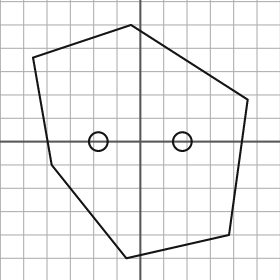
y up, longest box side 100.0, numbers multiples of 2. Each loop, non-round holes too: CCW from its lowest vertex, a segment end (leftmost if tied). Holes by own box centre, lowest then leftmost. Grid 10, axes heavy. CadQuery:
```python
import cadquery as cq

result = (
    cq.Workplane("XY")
    .moveTo(-6.0, -50.0)
    .lineTo(38.0, -40.0)
    .lineTo(46.0, 18.0)
    .lineTo(-4.0, 50.0)
    .lineTo(-46.0, 36.0)
    .lineTo(-38.0, -10.0)
    .close()
    .moveTo(-18.0, 0.0)
    .circle(4.0)
    .moveTo(18.0, 0.0)
    .circle(4.0)
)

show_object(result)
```